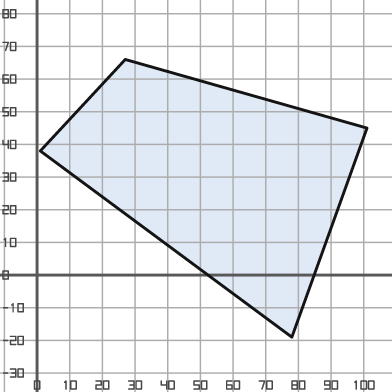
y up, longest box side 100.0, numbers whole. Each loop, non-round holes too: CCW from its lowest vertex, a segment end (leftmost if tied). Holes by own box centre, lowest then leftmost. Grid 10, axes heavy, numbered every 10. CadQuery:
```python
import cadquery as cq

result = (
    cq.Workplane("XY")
    .moveTo(78.0, -19.0)
    .lineTo(101.0, 45.0)
    .lineTo(27.0, 66.0)
    .lineTo(1.0, 38.0)
    .close()
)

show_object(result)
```